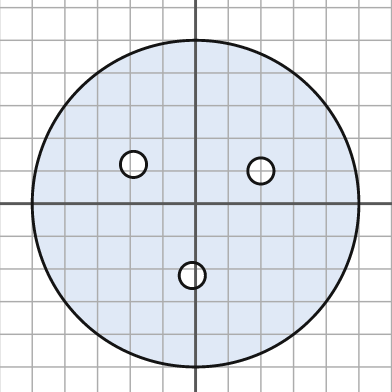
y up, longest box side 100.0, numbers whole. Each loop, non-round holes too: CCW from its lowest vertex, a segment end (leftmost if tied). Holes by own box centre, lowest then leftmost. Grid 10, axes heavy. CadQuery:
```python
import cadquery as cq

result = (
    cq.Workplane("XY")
    .moveTo(0.0, 0.0)
    .circle(50.0)
    .moveTo(-1.0, -22.0)
    .circle(4.0)
    .moveTo(20.0, 10.0)
    .circle(4.0)
    .moveTo(-19.0, 12.0)
    .circle(4.0)
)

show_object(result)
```